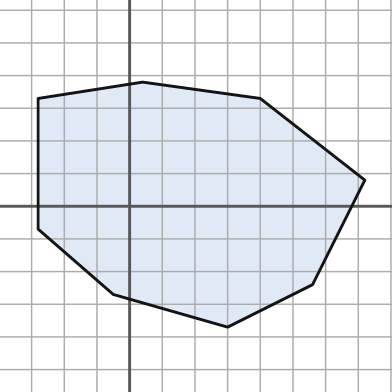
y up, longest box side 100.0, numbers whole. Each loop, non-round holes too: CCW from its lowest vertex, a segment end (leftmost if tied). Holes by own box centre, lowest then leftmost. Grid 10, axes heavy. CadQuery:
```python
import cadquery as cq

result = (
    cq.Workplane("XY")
    .moveTo(30.0, -37.0)
    .lineTo(56.0, -24.0)
    .lineTo(72.0, 8.0)
    .lineTo(40.0, 33.0)
    .lineTo(4.0, 38.0)
    .lineTo(-28.0, 33.0)
    .lineTo(-28.0, -7.0)
    .lineTo(-5.0, -27.0)
    .close()
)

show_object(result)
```